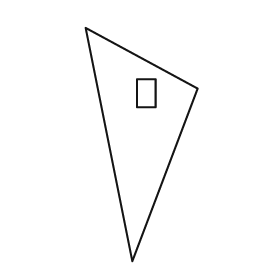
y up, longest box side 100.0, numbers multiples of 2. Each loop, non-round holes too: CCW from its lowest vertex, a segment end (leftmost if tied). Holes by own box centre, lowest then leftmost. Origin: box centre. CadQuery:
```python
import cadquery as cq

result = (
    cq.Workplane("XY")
    .moveTo(-4.0, -50.0)
    .lineTo(24.0, 24.0)
    .lineTo(-24.0, 50.0)
    .close()
    .moveTo(-2.0, 16.0)
    .lineTo(6.0, 16.0)
    .lineTo(6.0, 28.0)
    .lineTo(-2.0, 28.0)
    .close()
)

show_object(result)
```